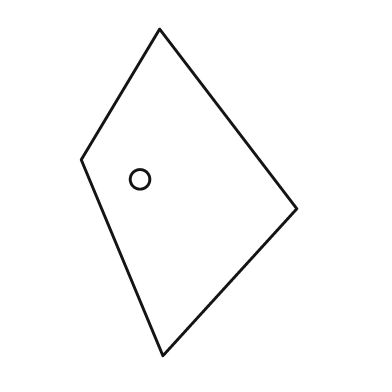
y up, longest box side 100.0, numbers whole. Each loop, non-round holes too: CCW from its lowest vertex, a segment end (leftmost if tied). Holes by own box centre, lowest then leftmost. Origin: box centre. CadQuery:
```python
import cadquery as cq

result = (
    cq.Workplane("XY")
    .moveTo(-8.0, -50.0)
    .lineTo(33.0, -5.0)
    .lineTo(-9.0, 50.0)
    .lineTo(-33.0, 10.0)
    .close()
    .moveTo(-15.0, 4.0)
    .circle(3.0)
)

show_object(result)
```